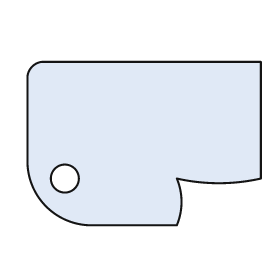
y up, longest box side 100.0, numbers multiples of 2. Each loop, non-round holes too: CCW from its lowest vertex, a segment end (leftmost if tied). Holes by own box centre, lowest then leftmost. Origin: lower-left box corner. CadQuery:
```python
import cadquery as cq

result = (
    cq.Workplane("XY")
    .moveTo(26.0, 0.0)
    .lineTo(64.0, 0.0)
    .threePointArc((66.0, 10.0), (64.0, 20.0))
    .threePointArc((82.0, 18.0), (100.0, 20.0))
    .lineTo(100.0, 70.0)
    .lineTo(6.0, 70.0)
    .threePointArc((2.0, 68.0), (0.0, 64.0))
    .lineTo(0.0, 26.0)
    .threePointArc((8.0, 8.0), (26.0, 0.0))
    .close()
    .moveTo(16.0, 20.0)
    .circle(6.0)
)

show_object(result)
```